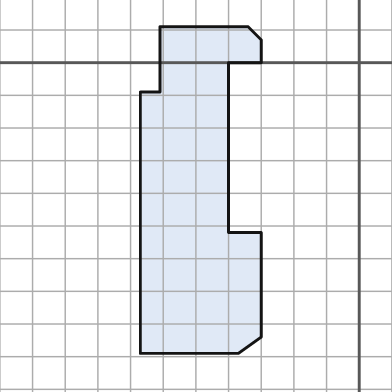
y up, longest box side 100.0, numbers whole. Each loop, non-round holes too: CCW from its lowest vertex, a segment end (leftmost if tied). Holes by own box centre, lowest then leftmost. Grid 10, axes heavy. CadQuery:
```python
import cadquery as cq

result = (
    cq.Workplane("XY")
    .moveTo(-67.0, -89.0)
    .lineTo(-37.0, -89.0)
    .lineTo(-30.0, -84.0)
    .lineTo(-30.0, -52.0)
    .lineTo(-40.0, -52.0)
    .lineTo(-40.0, 0.0)
    .lineTo(-30.0, 0.0)
    .lineTo(-30.0, 7.0)
    .lineTo(-34.0, 11.0)
    .lineTo(-61.0, 11.0)
    .lineTo(-61.0, -9.0)
    .lineTo(-67.0, -9.0)
    .close()
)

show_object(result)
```